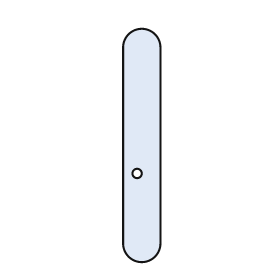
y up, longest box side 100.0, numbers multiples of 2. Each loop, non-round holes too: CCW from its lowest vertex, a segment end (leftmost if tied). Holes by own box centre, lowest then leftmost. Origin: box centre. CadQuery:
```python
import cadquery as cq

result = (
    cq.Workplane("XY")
    .moveTo(-8.0, -42.0)
    .threePointArc((0.0, -50.0), (8.0, -42.0))
    .lineTo(8.0, 42.0)
    .threePointArc((0.0, 50.0), (-8.0, 42.0))
    .close()
    .moveTo(-2.0, -12.0)
    .circle(2.0)
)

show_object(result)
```